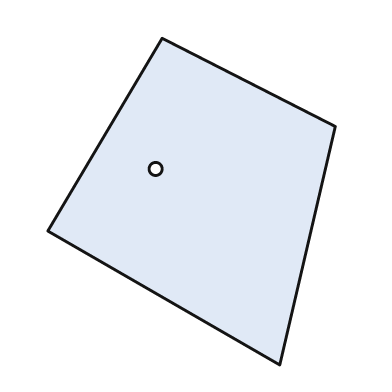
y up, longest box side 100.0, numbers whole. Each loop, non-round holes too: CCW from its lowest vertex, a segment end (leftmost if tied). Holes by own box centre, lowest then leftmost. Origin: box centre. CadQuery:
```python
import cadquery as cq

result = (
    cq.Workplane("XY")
    .moveTo(27.0, -50.0)
    .lineTo(44.0, 23.0)
    .lineTo(-9.0, 50.0)
    .lineTo(-44.0, -9.0)
    .close()
    .moveTo(-11.0, 10.0)
    .circle(2.0)
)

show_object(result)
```